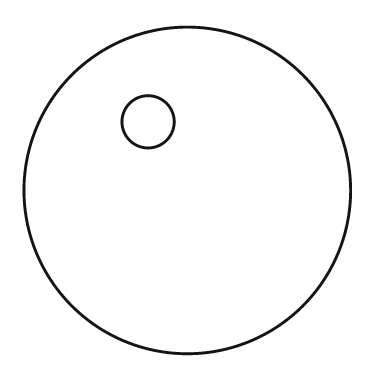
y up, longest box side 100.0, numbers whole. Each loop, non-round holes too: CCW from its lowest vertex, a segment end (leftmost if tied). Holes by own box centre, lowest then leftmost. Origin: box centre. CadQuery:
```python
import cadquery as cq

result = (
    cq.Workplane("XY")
    .moveTo(0.0, 0.0)
    .circle(50.0)
    .moveTo(-12.0, 21.0)
    .circle(8.0)
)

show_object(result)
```